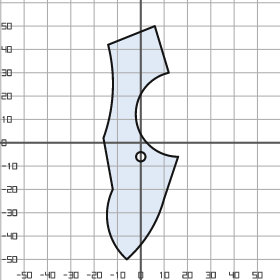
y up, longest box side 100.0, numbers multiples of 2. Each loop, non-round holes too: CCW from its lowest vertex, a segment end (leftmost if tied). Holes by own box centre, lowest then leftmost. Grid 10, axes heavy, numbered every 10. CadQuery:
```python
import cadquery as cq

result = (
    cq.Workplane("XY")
    .moveTo(-6.0, -50.0)
    .threePointArc((4.0, -38.0), (10.0, -24.0))
    .lineTo(16.0, -6.0)
    .threePointArc((-2.0, 10.0), (12.0, 30.0))
    .lineTo(6.0, 50.0)
    .lineTo(-14.0, 42.0)
    .threePointArc((-12.0, 22.0), (-16.0, 2.0))
    .lineTo(-12.0, -20.0)
    .threePointArc((-14.0, -36.0), (-6.0, -50.0))
    .close()
    .moveTo(0.0, -6.0)
    .circle(2.0)
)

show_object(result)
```